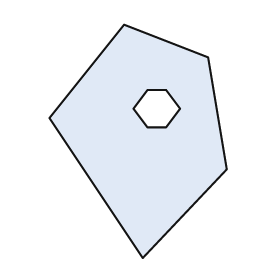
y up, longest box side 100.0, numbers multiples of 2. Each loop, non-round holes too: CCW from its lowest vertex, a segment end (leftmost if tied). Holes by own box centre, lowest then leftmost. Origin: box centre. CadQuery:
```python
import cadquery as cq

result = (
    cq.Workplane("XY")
    .moveTo(2.0, -50.0)
    .lineTo(38.0, -12.0)
    .lineTo(30.0, 36.0)
    .lineTo(-6.0, 50.0)
    .lineTo(-38.0, 10.0)
    .close()
    .moveTo(4.0, 6.0)
    .lineTo(12.0, 6.0)
    .lineTo(18.0, 14.0)
    .lineTo(12.0, 22.0)
    .lineTo(4.0, 22.0)
    .lineTo(-2.0, 14.0)
    .close()
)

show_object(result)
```